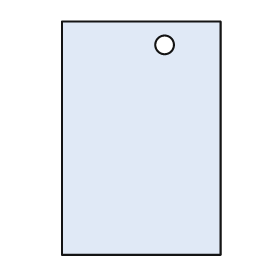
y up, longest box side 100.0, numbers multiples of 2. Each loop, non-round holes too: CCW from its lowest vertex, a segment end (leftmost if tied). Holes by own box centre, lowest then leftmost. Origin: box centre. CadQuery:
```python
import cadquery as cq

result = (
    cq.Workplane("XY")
    .moveTo(-34.0, -50.0)
    .lineTo(34.0, -50.0)
    .lineTo(34.0, 50.0)
    .lineTo(-34.0, 50.0)
    .close()
    .moveTo(10.0, 40.0)
    .circle(4.0)
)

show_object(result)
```